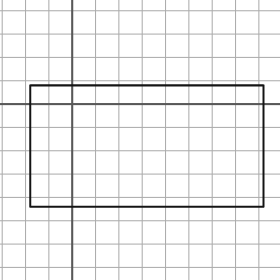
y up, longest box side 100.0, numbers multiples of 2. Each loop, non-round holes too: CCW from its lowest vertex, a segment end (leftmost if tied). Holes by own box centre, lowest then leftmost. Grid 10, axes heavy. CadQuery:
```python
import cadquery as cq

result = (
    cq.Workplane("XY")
    .moveTo(-18.0, -44.0)
    .lineTo(82.0, -44.0)
    .lineTo(82.0, 8.0)
    .lineTo(-18.0, 8.0)
    .close()
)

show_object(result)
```